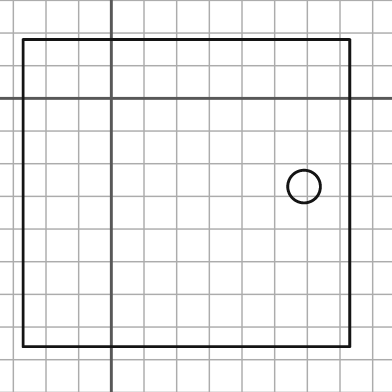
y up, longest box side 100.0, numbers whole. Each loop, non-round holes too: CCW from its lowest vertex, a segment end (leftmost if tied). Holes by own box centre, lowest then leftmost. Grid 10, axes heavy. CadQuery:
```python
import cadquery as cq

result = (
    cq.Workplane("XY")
    .moveTo(-27.0, -76.0)
    .lineTo(73.0, -76.0)
    .lineTo(73.0, 18.0)
    .lineTo(-27.0, 18.0)
    .close()
    .moveTo(59.0, -27.0)
    .circle(5.0)
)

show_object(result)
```